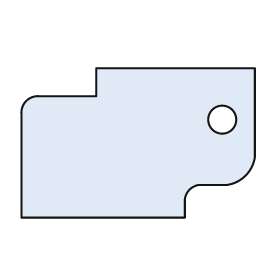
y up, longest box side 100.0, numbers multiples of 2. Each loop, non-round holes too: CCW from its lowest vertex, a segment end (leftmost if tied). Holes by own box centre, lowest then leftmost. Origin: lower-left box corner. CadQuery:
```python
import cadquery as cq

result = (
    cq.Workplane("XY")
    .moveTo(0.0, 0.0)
    .lineTo(70.0, 0.0)
    .lineTo(70.0, 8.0)
    .threePointArc((72.0, 12.0), (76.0, 14.0))
    .lineTo(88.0, 14.0)
    .threePointArc((96.0, 18.0), (100.0, 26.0))
    .lineTo(100.0, 64.0)
    .lineTo(32.0, 64.0)
    .lineTo(32.0, 52.0)
    .lineTo(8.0, 52.0)
    .threePointArc((2.0, 50.0), (0.0, 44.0))
    .close()
    .moveTo(86.0, 42.0)
    .circle(6.0)
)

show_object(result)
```